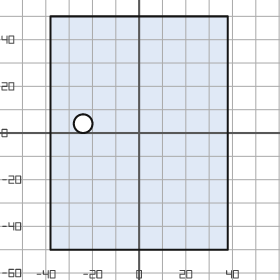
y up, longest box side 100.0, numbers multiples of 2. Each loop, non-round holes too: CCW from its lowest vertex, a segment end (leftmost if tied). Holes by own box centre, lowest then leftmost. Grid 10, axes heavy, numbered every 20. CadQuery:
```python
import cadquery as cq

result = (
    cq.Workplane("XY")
    .moveTo(-38.0, -50.0)
    .lineTo(38.0, -50.0)
    .lineTo(38.0, 50.0)
    .lineTo(-38.0, 50.0)
    .close()
    .moveTo(-24.0, 4.0)
    .circle(4.0)
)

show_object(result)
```